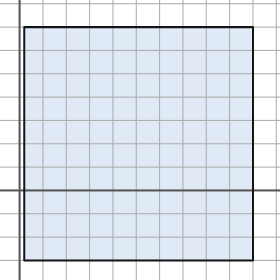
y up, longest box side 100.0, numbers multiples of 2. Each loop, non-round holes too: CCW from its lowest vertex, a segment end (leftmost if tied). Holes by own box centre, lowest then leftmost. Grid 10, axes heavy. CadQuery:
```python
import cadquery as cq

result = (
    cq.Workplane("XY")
    .moveTo(2.0, -30.0)
    .lineTo(100.0, -30.0)
    .lineTo(100.0, 70.0)
    .lineTo(2.0, 70.0)
    .close()
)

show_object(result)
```